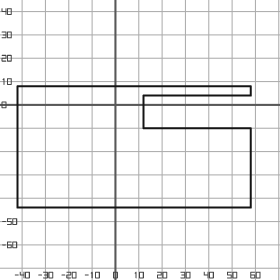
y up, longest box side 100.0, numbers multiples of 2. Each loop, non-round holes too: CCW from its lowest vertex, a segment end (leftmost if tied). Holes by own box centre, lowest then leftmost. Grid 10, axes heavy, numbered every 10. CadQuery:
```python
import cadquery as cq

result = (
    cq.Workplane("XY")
    .moveTo(-42.0, -44.0)
    .lineTo(58.0, -44.0)
    .lineTo(58.0, -10.0)
    .lineTo(12.0, -10.0)
    .lineTo(12.0, 4.0)
    .lineTo(58.0, 4.0)
    .lineTo(58.0, 8.0)
    .lineTo(-42.0, 8.0)
    .close()
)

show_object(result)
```